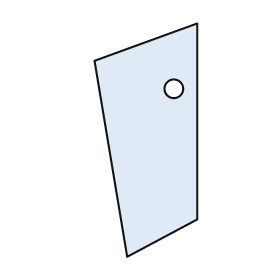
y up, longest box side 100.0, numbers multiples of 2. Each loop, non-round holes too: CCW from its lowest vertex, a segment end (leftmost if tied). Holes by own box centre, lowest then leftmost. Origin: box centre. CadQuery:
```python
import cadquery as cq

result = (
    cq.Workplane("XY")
    .moveTo(-8.0, -50.0)
    .lineTo(22.0, -34.0)
    .lineTo(22.0, 50.0)
    .lineTo(-22.0, 34.0)
    .close()
    .moveTo(12.0, 22.0)
    .circle(4.0)
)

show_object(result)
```